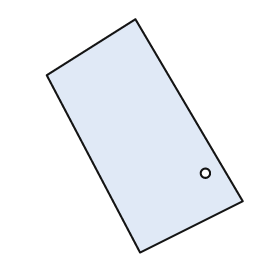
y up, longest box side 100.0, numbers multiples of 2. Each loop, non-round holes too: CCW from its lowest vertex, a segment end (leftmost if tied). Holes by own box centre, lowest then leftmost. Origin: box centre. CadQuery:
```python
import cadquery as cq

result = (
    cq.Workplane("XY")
    .moveTo(-2.0, -50.0)
    .lineTo(42.0, -28.0)
    .lineTo(-4.0, 50.0)
    .lineTo(-42.0, 26.0)
    .close()
    .moveTo(26.0, -16.0)
    .circle(2.0)
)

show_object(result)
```